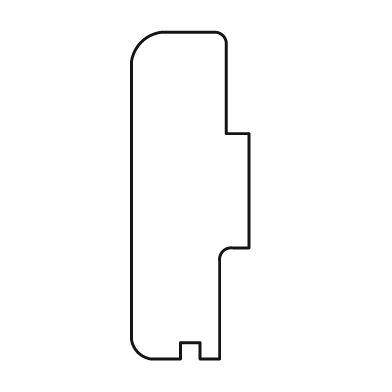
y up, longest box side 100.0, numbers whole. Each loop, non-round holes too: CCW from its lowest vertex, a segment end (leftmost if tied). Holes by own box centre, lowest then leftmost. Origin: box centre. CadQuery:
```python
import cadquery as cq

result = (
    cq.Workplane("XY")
    .moveTo(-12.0, -50.0)
    .lineTo(-3.0, -50.0)
    .lineTo(-3.0, -45.0)
    .lineTo(3.0, -45.0)
    .lineTo(3.0, -50.0)
    .lineTo(9.0, -50.0)
    .lineTo(9.0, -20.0)
    .threePointArc((10.0, -17.0), (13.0, -16.0))
    .lineTo(18.0, -16.0)
    .lineTo(18.0, 19.0)
    .lineTo(11.0, 19.0)
    .lineTo(11.0, 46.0)
    .threePointArc((10.0, 49.0), (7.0, 50.0))
    .lineTo(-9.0, 50.0)
    .threePointArc((-15.0, 47.0), (-18.0, 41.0))
    .lineTo(-18.0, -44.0)
    .threePointArc((-16.0, -48.0), (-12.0, -50.0))
    .close()
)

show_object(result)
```